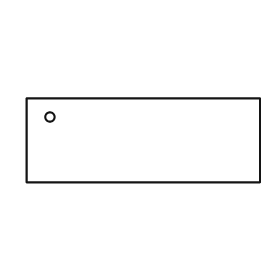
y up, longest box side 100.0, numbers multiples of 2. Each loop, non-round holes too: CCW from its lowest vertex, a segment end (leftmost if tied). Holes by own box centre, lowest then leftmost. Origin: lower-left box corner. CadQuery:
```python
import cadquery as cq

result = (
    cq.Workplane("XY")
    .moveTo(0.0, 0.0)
    .lineTo(100.0, 0.0)
    .lineTo(100.0, 36.0)
    .lineTo(0.0, 36.0)
    .close()
    .moveTo(10.0, 28.0)
    .circle(2.0)
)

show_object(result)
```